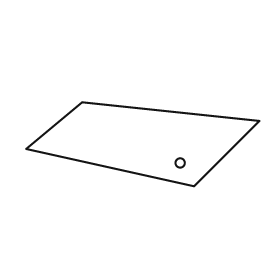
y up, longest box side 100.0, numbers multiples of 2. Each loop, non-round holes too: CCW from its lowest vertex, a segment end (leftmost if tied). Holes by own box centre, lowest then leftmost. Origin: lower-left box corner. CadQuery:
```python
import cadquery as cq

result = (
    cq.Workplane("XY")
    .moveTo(72.0, 0.0)
    .lineTo(100.0, 28.0)
    .lineTo(24.0, 36.0)
    .lineTo(0.0, 16.0)
    .close()
    .moveTo(66.0, 10.0)
    .circle(2.0)
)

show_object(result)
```